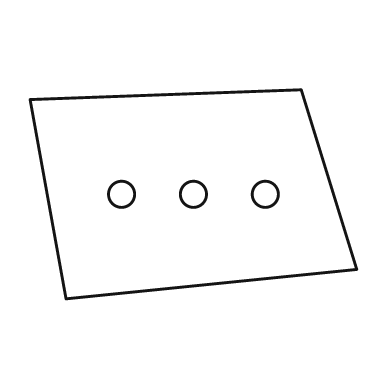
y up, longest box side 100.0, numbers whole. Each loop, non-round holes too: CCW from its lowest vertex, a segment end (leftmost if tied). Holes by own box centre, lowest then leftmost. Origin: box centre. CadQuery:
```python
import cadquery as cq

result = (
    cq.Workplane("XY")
    .moveTo(-39.0, -32.0)
    .lineTo(50.0, -23.0)
    .lineTo(33.0, 32.0)
    .lineTo(-50.0, 29.0)
    .close()
    .moveTo(-22.0, 0.0)
    .circle(4.0)
    .moveTo(0.0, 0.0)
    .circle(4.0)
    .moveTo(22.0, 0.0)
    .circle(4.0)
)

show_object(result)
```